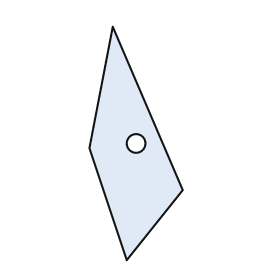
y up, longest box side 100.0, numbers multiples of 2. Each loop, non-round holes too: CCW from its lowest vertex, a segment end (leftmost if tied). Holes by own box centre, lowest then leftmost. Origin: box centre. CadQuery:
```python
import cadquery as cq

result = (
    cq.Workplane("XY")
    .moveTo(-4.0, -50.0)
    .lineTo(20.0, -20.0)
    .lineTo(-10.0, 50.0)
    .lineTo(-20.0, -2.0)
    .close()
    .moveTo(0.0, 0.0)
    .circle(4.0)
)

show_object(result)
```